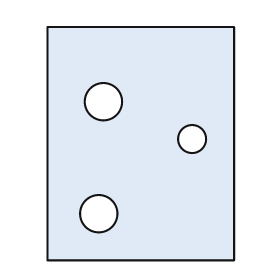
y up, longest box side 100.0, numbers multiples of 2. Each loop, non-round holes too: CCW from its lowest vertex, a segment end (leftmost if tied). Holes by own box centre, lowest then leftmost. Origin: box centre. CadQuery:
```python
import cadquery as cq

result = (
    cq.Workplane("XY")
    .moveTo(-40.0, -50.0)
    .lineTo(40.0, -50.0)
    .lineTo(40.0, 50.0)
    .lineTo(-40.0, 50.0)
    .close()
    .moveTo(-18.0, -30.0)
    .circle(8.0)
    .moveTo(22.0, 2.0)
    .circle(6.0)
    .moveTo(-16.0, 18.0)
    .circle(8.0)
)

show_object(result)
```